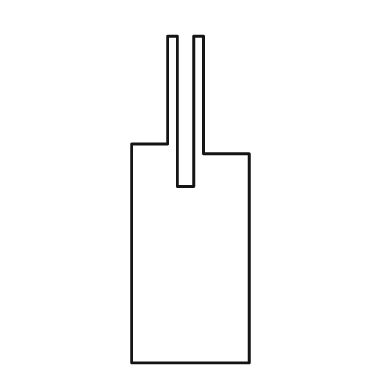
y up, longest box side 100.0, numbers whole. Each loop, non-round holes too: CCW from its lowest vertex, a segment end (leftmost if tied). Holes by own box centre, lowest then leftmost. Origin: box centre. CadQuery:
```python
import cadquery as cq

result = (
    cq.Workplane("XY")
    .moveTo(-18.0, -50.0)
    .lineTo(18.0, -50.0)
    .lineTo(18.0, 14.0)
    .lineTo(4.0, 14.0)
    .lineTo(4.0, 50.0)
    .lineTo(1.0, 50.0)
    .lineTo(1.0, 4.0)
    .lineTo(-4.0, 4.0)
    .lineTo(-4.0, 50.0)
    .lineTo(-7.0, 50.0)
    .lineTo(-7.0, 17.0)
    .lineTo(-18.0, 17.0)
    .close()
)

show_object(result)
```